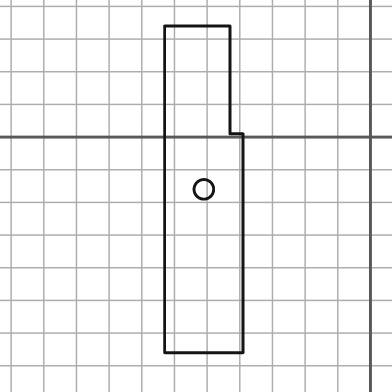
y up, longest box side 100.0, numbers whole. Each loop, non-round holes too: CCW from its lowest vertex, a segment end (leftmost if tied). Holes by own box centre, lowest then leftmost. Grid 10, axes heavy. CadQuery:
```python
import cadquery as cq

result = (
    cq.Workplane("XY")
    .moveTo(-63.0, -66.0)
    .lineTo(-39.0, -66.0)
    .lineTo(-39.0, 1.0)
    .lineTo(-43.0, 1.0)
    .lineTo(-43.0, 34.0)
    .lineTo(-63.0, 34.0)
    .close()
    .moveTo(-51.0, -16.0)
    .circle(3.0)
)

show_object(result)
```